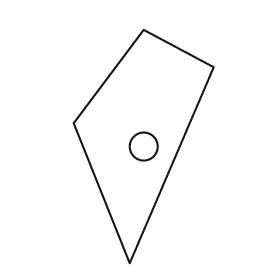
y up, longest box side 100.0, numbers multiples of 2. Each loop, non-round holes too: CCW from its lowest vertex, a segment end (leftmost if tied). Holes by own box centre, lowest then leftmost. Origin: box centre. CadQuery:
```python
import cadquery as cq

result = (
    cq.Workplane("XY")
    .moveTo(-6.0, -50.0)
    .lineTo(30.0, 34.0)
    .lineTo(0.0, 50.0)
    .lineTo(-30.0, 10.0)
    .close()
    .moveTo(0.0, 0.0)
    .circle(6.0)
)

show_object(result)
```